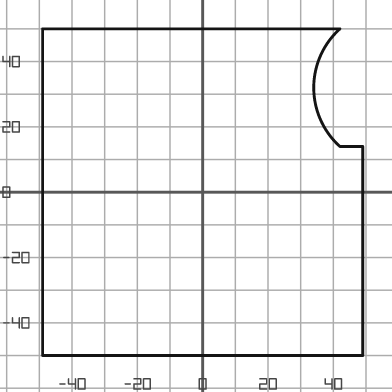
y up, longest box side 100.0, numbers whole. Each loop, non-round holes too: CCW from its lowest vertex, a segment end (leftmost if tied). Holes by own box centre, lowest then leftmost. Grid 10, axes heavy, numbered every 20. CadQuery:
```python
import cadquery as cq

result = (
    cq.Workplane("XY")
    .moveTo(-49.0, -50.0)
    .lineTo(49.0, -50.0)
    .lineTo(49.0, 14.0)
    .lineTo(42.0, 14.0)
    .threePointArc((34.0, 32.0), (42.0, 50.0))
    .lineTo(-49.0, 50.0)
    .close()
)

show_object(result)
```